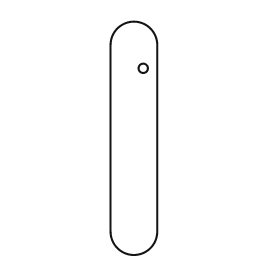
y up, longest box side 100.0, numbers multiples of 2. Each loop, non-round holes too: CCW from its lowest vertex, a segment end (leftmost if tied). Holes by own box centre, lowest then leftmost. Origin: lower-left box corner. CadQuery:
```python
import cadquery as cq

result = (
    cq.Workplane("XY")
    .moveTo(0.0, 10.0)
    .threePointArc((10.0, 0.0), (20.0, 10.0))
    .lineTo(20.0, 90.0)
    .threePointArc((10.0, 100.0), (0.0, 90.0))
    .close()
    .moveTo(14.0, 80.0)
    .circle(2.0)
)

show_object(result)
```